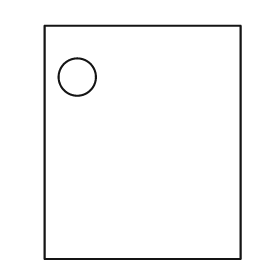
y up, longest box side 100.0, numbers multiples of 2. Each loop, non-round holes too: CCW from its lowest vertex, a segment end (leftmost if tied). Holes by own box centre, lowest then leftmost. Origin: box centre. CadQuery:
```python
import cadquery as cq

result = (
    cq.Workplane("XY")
    .moveTo(-42.0, -50.0)
    .lineTo(42.0, -50.0)
    .lineTo(42.0, 50.0)
    .lineTo(-42.0, 50.0)
    .close()
    .moveTo(-28.0, 28.0)
    .circle(8.0)
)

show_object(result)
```